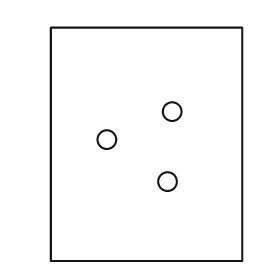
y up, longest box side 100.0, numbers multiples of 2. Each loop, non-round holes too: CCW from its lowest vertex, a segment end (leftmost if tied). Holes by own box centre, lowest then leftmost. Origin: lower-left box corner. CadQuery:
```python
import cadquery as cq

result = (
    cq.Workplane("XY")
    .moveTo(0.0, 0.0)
    .lineTo(82.0, 0.0)
    .lineTo(82.0, 100.0)
    .lineTo(0.0, 100.0)
    .close()
    .moveTo(50.0, 34.0)
    .circle(4.0)
    .moveTo(24.0, 52.0)
    .circle(4.0)
    .moveTo(52.0, 64.0)
    .circle(4.0)
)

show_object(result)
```